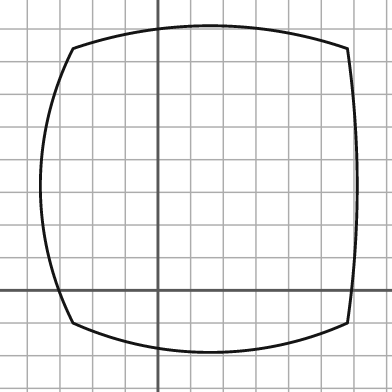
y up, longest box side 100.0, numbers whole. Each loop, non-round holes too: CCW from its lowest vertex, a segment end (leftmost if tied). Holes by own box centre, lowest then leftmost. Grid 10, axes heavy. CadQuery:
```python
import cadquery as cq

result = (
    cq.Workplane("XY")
    .moveTo(-26.0, -10.0)
    .threePointArc((16.0, -19.0), (58.0, -10.0))
    .threePointArc((61.0, 32.0), (58.0, 74.0))
    .threePointArc((16.0, 81.0), (-26.0, 74.0))
    .threePointArc((-36.0, 32.0), (-26.0, -10.0))
    .close()
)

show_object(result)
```